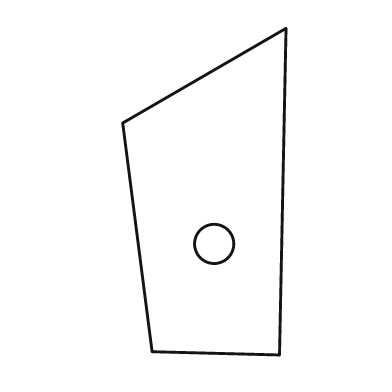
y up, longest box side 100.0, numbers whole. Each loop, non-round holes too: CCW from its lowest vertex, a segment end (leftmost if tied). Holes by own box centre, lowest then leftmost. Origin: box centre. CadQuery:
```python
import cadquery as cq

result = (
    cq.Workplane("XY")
    .moveTo(23.0, -50.0)
    .lineTo(25.0, 50.0)
    .lineTo(-25.0, 21.0)
    .lineTo(-16.0, -49.0)
    .close()
    .moveTo(3.0, -16.0)
    .circle(6.0)
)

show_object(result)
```